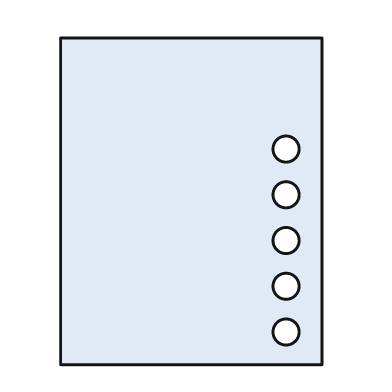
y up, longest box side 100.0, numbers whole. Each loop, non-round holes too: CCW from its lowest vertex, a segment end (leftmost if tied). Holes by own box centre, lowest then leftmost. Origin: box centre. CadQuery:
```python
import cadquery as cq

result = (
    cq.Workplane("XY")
    .moveTo(-40.0, -50.0)
    .lineTo(40.0, -50.0)
    .lineTo(40.0, 50.0)
    .lineTo(-40.0, 50.0)
    .close()
    .moveTo(29.0, -40.0)
    .circle(4.0)
    .moveTo(29.0, -26.0)
    .circle(4.0)
    .moveTo(29.0, -12.0)
    .circle(4.0)
    .moveTo(29.0, 2.0)
    .circle(4.0)
    .moveTo(29.0, 16.0)
    .circle(4.0)
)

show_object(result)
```